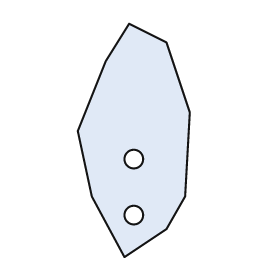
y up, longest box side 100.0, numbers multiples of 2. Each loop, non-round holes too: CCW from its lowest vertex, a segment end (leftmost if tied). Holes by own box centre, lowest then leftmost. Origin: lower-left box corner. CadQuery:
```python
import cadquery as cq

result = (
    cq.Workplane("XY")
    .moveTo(20.0, 0.0)
    .lineTo(38.0, 12.0)
    .lineTo(46.0, 26.0)
    .lineTo(48.0, 62.0)
    .lineTo(38.0, 92.0)
    .lineTo(22.0, 100.0)
    .lineTo(12.0, 84.0)
    .lineTo(0.0, 54.0)
    .lineTo(6.0, 26.0)
    .close()
    .moveTo(24.0, 18.0)
    .circle(4.0)
    .moveTo(24.0, 42.0)
    .circle(4.0)
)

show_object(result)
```